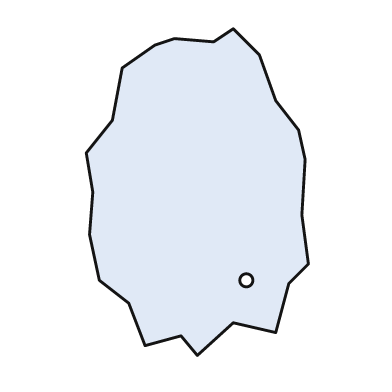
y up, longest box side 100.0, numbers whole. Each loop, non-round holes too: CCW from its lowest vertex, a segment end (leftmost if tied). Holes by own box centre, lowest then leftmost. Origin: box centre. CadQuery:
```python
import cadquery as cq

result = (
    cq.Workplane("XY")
    .moveTo(0.0, -50.0)
    .lineTo(11.0, -40.0)
    .lineTo(24.0, -43.0)
    .lineTo(28.0, -28.0)
    .lineTo(34.0, -22.0)
    .lineTo(32.0, -7.0)
    .lineTo(33.0, 10.0)
    .lineTo(31.0, 19.0)
    .lineTo(24.0, 28.0)
    .lineTo(19.0, 42.0)
    .lineTo(11.0, 50.0)
    .lineTo(5.0, 46.0)
    .lineTo(-7.0, 47.0)
    .lineTo(-13.0, 45.0)
    .lineTo(-23.0, 38.0)
    .lineTo(-26.0, 22.0)
    .lineTo(-34.0, 12.0)
    .lineTo(-32.0, 0.0)
    .lineTo(-33.0, -13.0)
    .lineTo(-30.0, -27.0)
    .lineTo(-21.0, -34.0)
    .lineTo(-16.0, -47.0)
    .lineTo(-5.0, -44.0)
    .close()
    .moveTo(15.0, -27.0)
    .circle(2.0)
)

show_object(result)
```